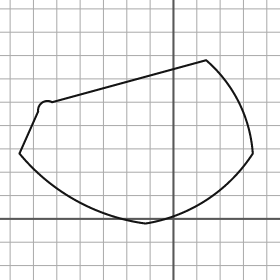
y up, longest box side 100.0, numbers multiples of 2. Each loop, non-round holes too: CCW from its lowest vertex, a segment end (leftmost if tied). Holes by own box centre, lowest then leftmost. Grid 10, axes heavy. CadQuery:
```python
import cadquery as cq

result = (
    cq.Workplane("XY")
    .moveTo(-12.0, -2.0)
    .threePointArc((14.0, 8.0), (34.0, 28.0))
    .threePointArc((28.0, 50.0), (14.0, 68.0))
    .lineTo(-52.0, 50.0)
    .threePointArc((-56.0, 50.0), (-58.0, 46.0))
    .lineTo(-66.0, 28.0)
    .threePointArc((-42.0, 8.0), (-12.0, -2.0))
    .close()
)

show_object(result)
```